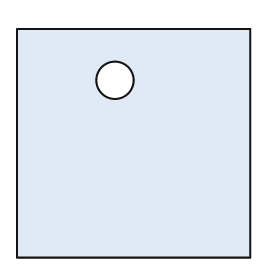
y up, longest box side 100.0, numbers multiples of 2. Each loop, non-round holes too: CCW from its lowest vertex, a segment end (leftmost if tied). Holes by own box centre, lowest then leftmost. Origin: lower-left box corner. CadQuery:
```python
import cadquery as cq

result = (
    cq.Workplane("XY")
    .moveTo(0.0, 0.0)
    .lineTo(100.0, 0.0)
    .lineTo(100.0, 98.0)
    .lineTo(0.0, 98.0)
    .close()
    .moveTo(42.0, 76.0)
    .circle(8.0)
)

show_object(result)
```